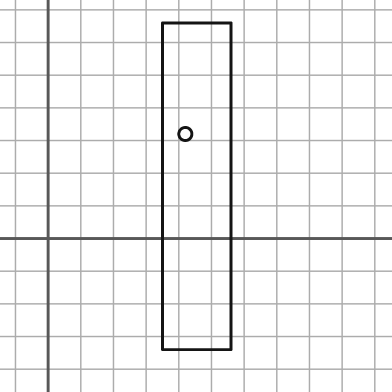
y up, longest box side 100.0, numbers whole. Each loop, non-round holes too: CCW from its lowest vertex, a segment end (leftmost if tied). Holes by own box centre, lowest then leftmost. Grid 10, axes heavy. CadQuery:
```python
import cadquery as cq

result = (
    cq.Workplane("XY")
    .moveTo(35.0, -34.0)
    .lineTo(56.0, -34.0)
    .lineTo(56.0, 66.0)
    .lineTo(35.0, 66.0)
    .close()
    .moveTo(42.0, 32.0)
    .circle(2.0)
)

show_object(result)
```